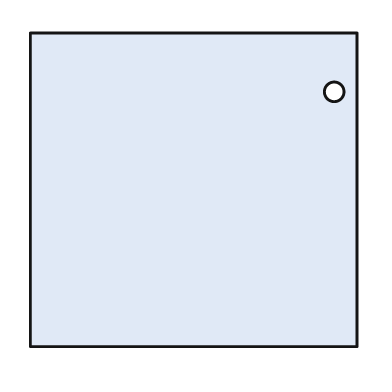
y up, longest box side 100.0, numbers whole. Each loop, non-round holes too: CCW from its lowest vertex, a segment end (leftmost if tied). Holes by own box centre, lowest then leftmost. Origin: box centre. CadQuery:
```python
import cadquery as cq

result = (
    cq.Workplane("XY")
    .moveTo(-50.0, -48.0)
    .lineTo(50.0, -48.0)
    .lineTo(50.0, 48.0)
    .lineTo(-50.0, 48.0)
    .close()
    .moveTo(43.0, 30.0)
    .circle(3.0)
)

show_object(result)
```